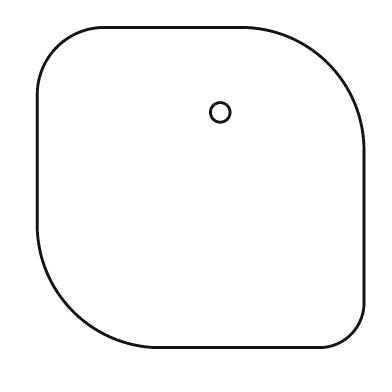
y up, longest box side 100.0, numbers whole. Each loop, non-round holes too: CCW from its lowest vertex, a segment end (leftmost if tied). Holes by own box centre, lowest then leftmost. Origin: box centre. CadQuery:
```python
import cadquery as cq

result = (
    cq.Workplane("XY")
    .moveTo(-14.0, -49.0)
    .lineTo(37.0, -49.0)
    .threePointArc((46.0, -45.0), (50.0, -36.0))
    .lineTo(50.0, 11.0)
    .threePointArc((39.0, 38.0), (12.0, 49.0))
    .lineTo(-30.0, 49.0)
    .threePointArc((-44.0, 43.0), (-50.0, 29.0))
    .lineTo(-50.0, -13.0)
    .threePointArc((-39.0, -38.0), (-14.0, -49.0))
    .close()
    .moveTo(6.0, 23.0)
    .circle(3.0)
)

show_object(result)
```